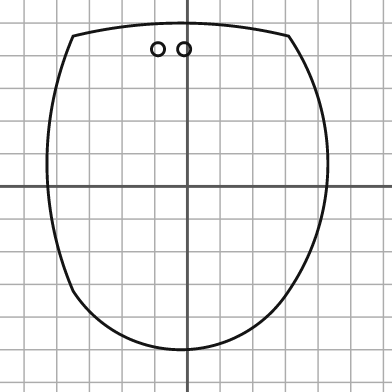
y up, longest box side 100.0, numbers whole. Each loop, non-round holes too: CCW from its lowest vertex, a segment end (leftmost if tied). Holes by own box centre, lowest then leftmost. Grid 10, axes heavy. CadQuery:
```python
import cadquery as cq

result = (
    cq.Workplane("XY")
    .moveTo(-35.0, -32.0)
    .threePointArc((-2.0, -50.0), (31.0, -32.0))
    .threePointArc((43.0, 7.0), (31.0, 46.0))
    .threePointArc((-2.0, 50.0), (-35.0, 46.0))
    .threePointArc((-43.0, 7.0), (-35.0, -32.0))
    .close()
    .moveTo(-9.0, 42.0)
    .circle(2.0)
    .moveTo(-1.0, 42.0)
    .circle(2.0)
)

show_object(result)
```